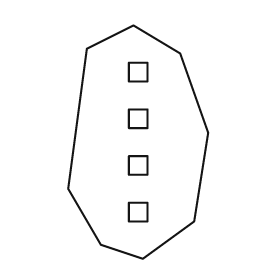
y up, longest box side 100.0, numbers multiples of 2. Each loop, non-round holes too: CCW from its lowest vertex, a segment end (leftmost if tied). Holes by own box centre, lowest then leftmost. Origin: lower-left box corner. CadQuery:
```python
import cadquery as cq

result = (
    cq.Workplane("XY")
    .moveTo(32.0, 0.0)
    .lineTo(54.0, 16.0)
    .lineTo(60.0, 54.0)
    .lineTo(48.0, 88.0)
    .lineTo(28.0, 100.0)
    .lineTo(8.0, 90.0)
    .lineTo(0.0, 30.0)
    .lineTo(14.0, 6.0)
    .close()
    .moveTo(26.0, 16.0)
    .lineTo(34.0, 16.0)
    .lineTo(34.0, 24.0)
    .lineTo(26.0, 24.0)
    .close()
    .moveTo(26.0, 36.0)
    .lineTo(34.0, 36.0)
    .lineTo(34.0, 44.0)
    .lineTo(26.0, 44.0)
    .close()
    .moveTo(26.0, 56.0)
    .lineTo(34.0, 56.0)
    .lineTo(34.0, 64.0)
    .lineTo(26.0, 64.0)
    .close()
    .moveTo(26.0, 76.0)
    .lineTo(34.0, 76.0)
    .lineTo(34.0, 84.0)
    .lineTo(26.0, 84.0)
    .close()
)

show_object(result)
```